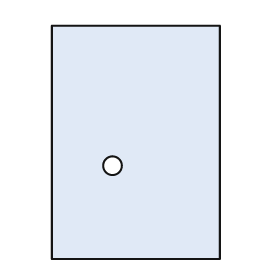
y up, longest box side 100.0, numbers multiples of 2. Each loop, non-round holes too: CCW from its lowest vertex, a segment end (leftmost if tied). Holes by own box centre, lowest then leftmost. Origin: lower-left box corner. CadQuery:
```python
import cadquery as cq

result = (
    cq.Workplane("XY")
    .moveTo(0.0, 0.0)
    .lineTo(72.0, 0.0)
    .lineTo(72.0, 100.0)
    .lineTo(0.0, 100.0)
    .close()
    .moveTo(26.0, 40.0)
    .circle(4.0)
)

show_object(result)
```